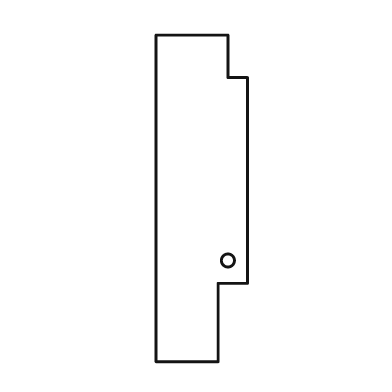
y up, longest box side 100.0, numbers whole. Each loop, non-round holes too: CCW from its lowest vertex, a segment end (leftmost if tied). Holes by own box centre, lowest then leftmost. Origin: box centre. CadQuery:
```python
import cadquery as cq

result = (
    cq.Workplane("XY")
    .moveTo(-14.0, -50.0)
    .lineTo(5.0, -50.0)
    .lineTo(5.0, -26.0)
    .lineTo(14.0, -26.0)
    .lineTo(14.0, 37.0)
    .lineTo(8.0, 37.0)
    .lineTo(8.0, 50.0)
    .lineTo(-14.0, 50.0)
    .close()
    .moveTo(8.0, -19.0)
    .circle(2.0)
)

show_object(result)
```